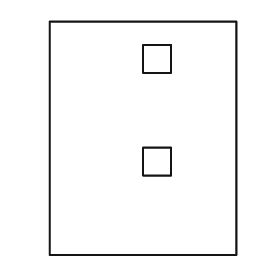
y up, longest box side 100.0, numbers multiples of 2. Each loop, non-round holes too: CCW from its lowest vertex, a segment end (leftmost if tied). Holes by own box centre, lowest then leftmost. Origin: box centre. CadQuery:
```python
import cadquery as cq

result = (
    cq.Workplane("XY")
    .moveTo(-40.0, -50.0)
    .lineTo(40.0, -50.0)
    .lineTo(40.0, 50.0)
    .lineTo(-40.0, 50.0)
    .close()
    .moveTo(0.0, -16.0)
    .lineTo(12.0, -16.0)
    .lineTo(12.0, -4.0)
    .lineTo(0.0, -4.0)
    .close()
    .moveTo(0.0, 28.0)
    .lineTo(12.0, 28.0)
    .lineTo(12.0, 40.0)
    .lineTo(0.0, 40.0)
    .close()
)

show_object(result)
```